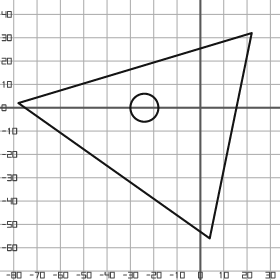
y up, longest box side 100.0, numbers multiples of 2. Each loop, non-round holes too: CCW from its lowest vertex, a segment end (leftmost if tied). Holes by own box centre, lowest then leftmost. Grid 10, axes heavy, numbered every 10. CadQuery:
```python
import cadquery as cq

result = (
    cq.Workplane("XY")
    .moveTo(4.0, -56.0)
    .lineTo(22.0, 32.0)
    .lineTo(-78.0, 2.0)
    .close()
    .moveTo(-24.0, 0.0)
    .circle(6.0)
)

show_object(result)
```